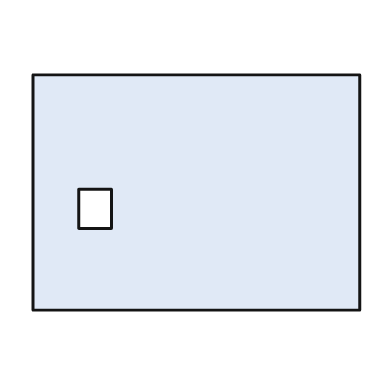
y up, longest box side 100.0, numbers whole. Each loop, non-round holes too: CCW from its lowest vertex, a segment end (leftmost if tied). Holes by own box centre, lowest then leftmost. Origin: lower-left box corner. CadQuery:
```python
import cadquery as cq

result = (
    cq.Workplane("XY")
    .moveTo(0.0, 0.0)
    .lineTo(100.0, 0.0)
    .lineTo(100.0, 72.0)
    .lineTo(0.0, 72.0)
    .close()
    .moveTo(14.0, 25.0)
    .lineTo(24.0, 25.0)
    .lineTo(24.0, 37.0)
    .lineTo(14.0, 37.0)
    .close()
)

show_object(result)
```